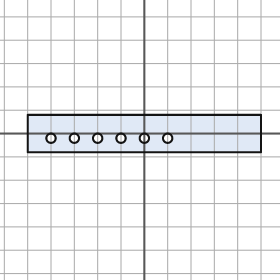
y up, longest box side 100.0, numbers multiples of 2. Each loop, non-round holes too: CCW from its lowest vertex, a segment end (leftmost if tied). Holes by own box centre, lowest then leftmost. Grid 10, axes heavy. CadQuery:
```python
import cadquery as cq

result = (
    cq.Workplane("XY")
    .moveTo(-50.0, -8.0)
    .lineTo(50.0, -8.0)
    .lineTo(50.0, 8.0)
    .lineTo(-50.0, 8.0)
    .close()
    .moveTo(-40.0, -2.0)
    .circle(2.0)
    .moveTo(-30.0, -2.0)
    .circle(2.0)
    .moveTo(-20.0, -2.0)
    .circle(2.0)
    .moveTo(-10.0, -2.0)
    .circle(2.0)
    .moveTo(0.0, -2.0)
    .circle(2.0)
    .moveTo(10.0, -2.0)
    .circle(2.0)
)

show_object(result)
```